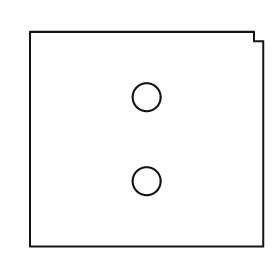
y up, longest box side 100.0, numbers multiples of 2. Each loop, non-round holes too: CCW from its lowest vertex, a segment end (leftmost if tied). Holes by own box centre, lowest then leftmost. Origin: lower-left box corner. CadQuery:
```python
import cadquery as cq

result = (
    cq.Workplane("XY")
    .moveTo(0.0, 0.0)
    .lineTo(100.0, 0.0)
    .lineTo(100.0, 88.0)
    .lineTo(96.0, 88.0)
    .lineTo(96.0, 92.0)
    .lineTo(0.0, 92.0)
    .close()
    .moveTo(50.0, 28.0)
    .circle(6.0)
    .moveTo(50.0, 64.0)
    .circle(6.0)
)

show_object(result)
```